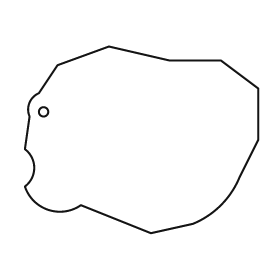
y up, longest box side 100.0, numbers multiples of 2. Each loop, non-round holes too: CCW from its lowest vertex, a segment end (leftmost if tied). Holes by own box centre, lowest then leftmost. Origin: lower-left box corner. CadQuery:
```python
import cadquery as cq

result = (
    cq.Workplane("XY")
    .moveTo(54.0, 0.0)
    .lineTo(72.0, 4.0)
    .threePointArc((84.0, 12.0), (92.0, 24.0))
    .lineTo(100.0, 40.0)
    .lineTo(100.0, 62.0)
    .lineTo(84.0, 74.0)
    .lineTo(62.0, 74.0)
    .lineTo(36.0, 80.0)
    .lineTo(14.0, 72.0)
    .lineTo(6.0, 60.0)
    .threePointArc((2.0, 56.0), (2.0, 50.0))
    .lineTo(0.0, 36.0)
    .threePointArc((4.0, 28.0), (0.0, 20.0))
    .threePointArc((10.0, 10.0), (24.0, 12.0))
    .close()
    .moveTo(8.0, 52.0)
    .circle(2.0)
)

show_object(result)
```